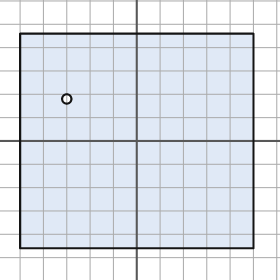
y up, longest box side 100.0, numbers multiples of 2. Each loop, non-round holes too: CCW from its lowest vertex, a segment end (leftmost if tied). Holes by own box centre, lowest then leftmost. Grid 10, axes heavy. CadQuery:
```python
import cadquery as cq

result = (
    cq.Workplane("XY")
    .moveTo(-50.0, -46.0)
    .lineTo(50.0, -46.0)
    .lineTo(50.0, 46.0)
    .lineTo(-50.0, 46.0)
    .close()
    .moveTo(-30.0, 18.0)
    .circle(2.0)
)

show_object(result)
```